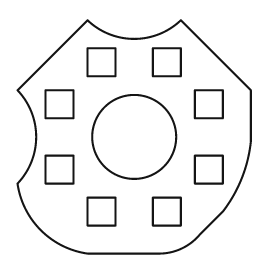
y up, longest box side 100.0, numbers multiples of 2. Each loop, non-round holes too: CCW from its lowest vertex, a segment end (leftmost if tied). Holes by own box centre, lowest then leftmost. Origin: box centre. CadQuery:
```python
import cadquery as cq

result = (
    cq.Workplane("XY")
    .moveTo(-20.0, -50.0)
    .lineTo(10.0, -50.0)
    .threePointArc((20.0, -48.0), (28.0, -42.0))
    .lineTo(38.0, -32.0)
    .threePointArc((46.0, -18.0), (50.0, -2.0))
    .lineTo(50.0, 20.0)
    .lineTo(20.0, 50.0)
    .threePointArc((0.0, 42.0), (-20.0, 50.0))
    .lineTo(-50.0, 20.0)
    .threePointArc((-42.0, 0.0), (-50.0, -20.0))
    .threePointArc((-40.0, -40.0), (-20.0, -50.0))
    .close()
    .moveTo(-20.0, -38.0)
    .lineTo(-8.0, -38.0)
    .lineTo(-8.0, -26.0)
    .lineTo(-20.0, -26.0)
    .close()
    .moveTo(8.0, -38.0)
    .lineTo(20.0, -38.0)
    .lineTo(20.0, -26.0)
    .lineTo(8.0, -26.0)
    .close()
    .moveTo(-38.0, -20.0)
    .lineTo(-26.0, -20.0)
    .lineTo(-26.0, -8.0)
    .lineTo(-38.0, -8.0)
    .close()
    .moveTo(26.0, -20.0)
    .lineTo(38.0, -20.0)
    .lineTo(38.0, -8.0)
    .lineTo(26.0, -8.0)
    .close()
    .moveTo(0.0, 0.0)
    .circle(18.0)
    .moveTo(-38.0, 8.0)
    .lineTo(-26.0, 8.0)
    .lineTo(-26.0, 20.0)
    .lineTo(-38.0, 20.0)
    .close()
    .moveTo(26.0, 8.0)
    .lineTo(38.0, 8.0)
    .lineTo(38.0, 20.0)
    .lineTo(26.0, 20.0)
    .close()
    .moveTo(-20.0, 26.0)
    .lineTo(-8.0, 26.0)
    .lineTo(-8.0, 38.0)
    .lineTo(-20.0, 38.0)
    .close()
    .moveTo(8.0, 26.0)
    .lineTo(20.0, 26.0)
    .lineTo(20.0, 38.0)
    .lineTo(8.0, 38.0)
    .close()
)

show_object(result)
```